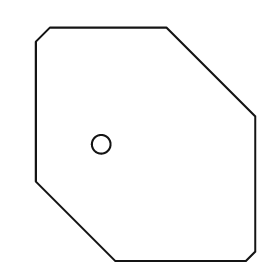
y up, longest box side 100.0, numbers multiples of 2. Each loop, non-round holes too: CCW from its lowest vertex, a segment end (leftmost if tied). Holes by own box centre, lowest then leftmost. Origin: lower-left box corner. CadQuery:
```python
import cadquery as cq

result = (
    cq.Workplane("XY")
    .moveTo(34.0, 0.0)
    .lineTo(90.0, 0.0)
    .lineTo(94.0, 4.0)
    .lineTo(94.0, 62.0)
    .lineTo(56.0, 100.0)
    .lineTo(6.0, 100.0)
    .lineTo(0.0, 94.0)
    .lineTo(0.0, 34.0)
    .close()
    .moveTo(28.0, 50.0)
    .circle(4.0)
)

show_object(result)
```